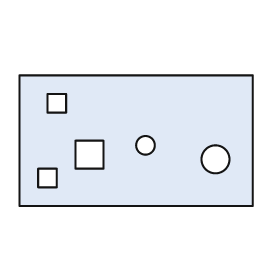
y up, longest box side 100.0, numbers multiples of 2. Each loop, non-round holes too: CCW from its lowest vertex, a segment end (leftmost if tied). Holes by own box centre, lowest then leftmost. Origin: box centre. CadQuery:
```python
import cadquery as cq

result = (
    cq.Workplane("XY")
    .moveTo(-50.0, -28.0)
    .lineTo(50.0, -28.0)
    .lineTo(50.0, 28.0)
    .lineTo(-50.0, 28.0)
    .close()
    .moveTo(-42.0, -20.0)
    .lineTo(-34.0, -20.0)
    .lineTo(-34.0, -12.0)
    .lineTo(-42.0, -12.0)
    .close()
    .moveTo(34.0, -8.0)
    .circle(6.0)
    .moveTo(-26.0, -12.0)
    .lineTo(-14.0, -12.0)
    .lineTo(-14.0, 0.0)
    .lineTo(-26.0, 0.0)
    .close()
    .moveTo(4.0, -2.0)
    .circle(4.0)
    .moveTo(-38.0, 12.0)
    .lineTo(-30.0, 12.0)
    .lineTo(-30.0, 20.0)
    .lineTo(-38.0, 20.0)
    .close()
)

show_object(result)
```